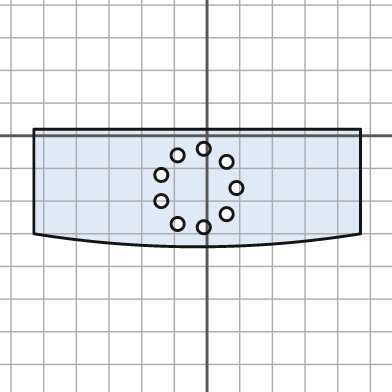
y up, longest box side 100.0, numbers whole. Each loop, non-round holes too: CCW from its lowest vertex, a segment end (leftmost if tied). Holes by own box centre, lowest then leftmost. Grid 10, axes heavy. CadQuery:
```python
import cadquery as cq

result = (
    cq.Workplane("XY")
    .moveTo(-53.0, -30.0)
    .threePointArc((-3.0, -34.0), (47.0, -30.0))
    .lineTo(47.0, 2.0)
    .lineTo(-53.0, 2.0)
    .close()
    .moveTo(-1.0, -28.0)
    .circle(2.0)
    .moveTo(-9.0, -27.0)
    .circle(2.0)
    .moveTo(6.0, -24.0)
    .circle(2.0)
    .moveTo(-14.0, -20.0)
    .circle(2.0)
    .moveTo(9.0, -16.0)
    .circle(2.0)
    .moveTo(-14.0, -12.0)
    .circle(2.0)
    .moveTo(6.0, -8.0)
    .circle(2.0)
    .moveTo(-9.0, -6.0)
    .circle(2.0)
    .moveTo(-1.0, -4.0)
    .circle(2.0)
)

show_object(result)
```